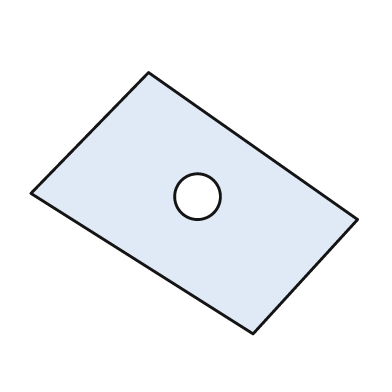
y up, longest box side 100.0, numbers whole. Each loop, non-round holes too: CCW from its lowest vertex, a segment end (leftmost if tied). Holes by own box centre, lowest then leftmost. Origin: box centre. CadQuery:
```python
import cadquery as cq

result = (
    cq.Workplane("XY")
    .moveTo(18.0, -40.0)
    .lineTo(50.0, -5.0)
    .lineTo(-14.0, 40.0)
    .lineTo(-50.0, 3.0)
    .close()
    .moveTo(1.0, 2.0)
    .circle(7.0)
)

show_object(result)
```